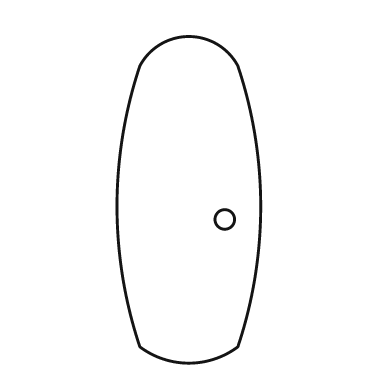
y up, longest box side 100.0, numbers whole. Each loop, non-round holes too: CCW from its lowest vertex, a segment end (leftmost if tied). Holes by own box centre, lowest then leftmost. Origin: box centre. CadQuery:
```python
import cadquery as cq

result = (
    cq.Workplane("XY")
    .moveTo(-15.0, -45.0)
    .threePointArc((0.0, -50.0), (15.0, -45.0))
    .threePointArc((22.0, -2.0), (15.0, 41.0))
    .threePointArc((0.0, 50.0), (-15.0, 41.0))
    .threePointArc((-22.0, -2.0), (-15.0, -45.0))
    .close()
    .moveTo(11.0, -6.0)
    .circle(3.0)
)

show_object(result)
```